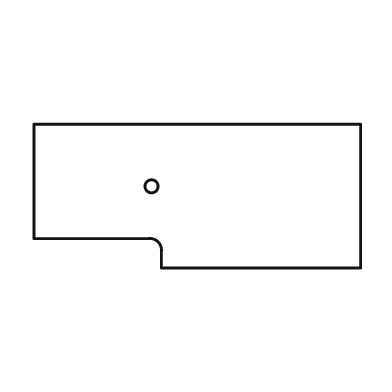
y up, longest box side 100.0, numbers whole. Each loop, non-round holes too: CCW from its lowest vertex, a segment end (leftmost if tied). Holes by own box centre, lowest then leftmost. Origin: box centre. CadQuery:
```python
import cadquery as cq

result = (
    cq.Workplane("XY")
    .moveTo(-11.0, -22.0)
    .lineTo(50.0, -22.0)
    .lineTo(50.0, 22.0)
    .lineTo(-50.0, 22.0)
    .lineTo(-50.0, -13.0)
    .lineTo(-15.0, -13.0)
    .threePointArc((-12.0, -14.0), (-11.0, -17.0))
    .close()
    .moveTo(-14.0, 3.0)
    .circle(2.0)
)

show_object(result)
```